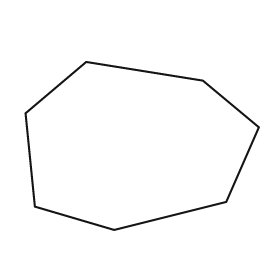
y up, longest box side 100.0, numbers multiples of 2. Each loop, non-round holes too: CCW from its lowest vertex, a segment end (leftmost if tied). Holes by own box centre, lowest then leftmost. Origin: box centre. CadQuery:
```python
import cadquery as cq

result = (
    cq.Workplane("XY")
    .moveTo(-12.0, -36.0)
    .lineTo(36.0, -24.0)
    .lineTo(50.0, 8.0)
    .lineTo(26.0, 28.0)
    .lineTo(-24.0, 36.0)
    .lineTo(-50.0, 14.0)
    .lineTo(-46.0, -26.0)
    .close()
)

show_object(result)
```